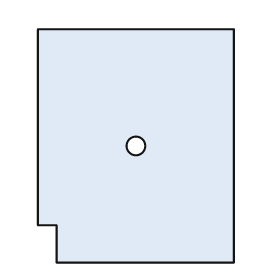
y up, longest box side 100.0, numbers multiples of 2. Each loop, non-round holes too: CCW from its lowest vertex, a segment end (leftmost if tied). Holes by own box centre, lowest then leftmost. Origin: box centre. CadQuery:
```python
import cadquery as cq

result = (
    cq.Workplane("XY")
    .moveTo(-34.0, -50.0)
    .lineTo(42.0, -50.0)
    .lineTo(42.0, 50.0)
    .lineTo(-42.0, 50.0)
    .lineTo(-42.0, -34.0)
    .lineTo(-34.0, -34.0)
    .close()
    .moveTo(0.0, 0.0)
    .circle(4.0)
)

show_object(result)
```